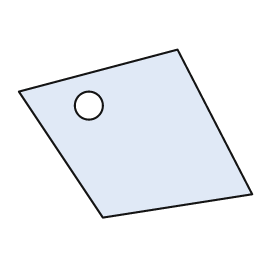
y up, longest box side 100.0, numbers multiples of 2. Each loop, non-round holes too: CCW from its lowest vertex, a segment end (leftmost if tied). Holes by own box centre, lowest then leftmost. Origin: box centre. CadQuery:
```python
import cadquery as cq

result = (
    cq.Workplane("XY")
    .moveTo(-14.0, -36.0)
    .lineTo(50.0, -26.0)
    .lineTo(18.0, 36.0)
    .lineTo(-50.0, 18.0)
    .close()
    .moveTo(-20.0, 12.0)
    .circle(6.0)
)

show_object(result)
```